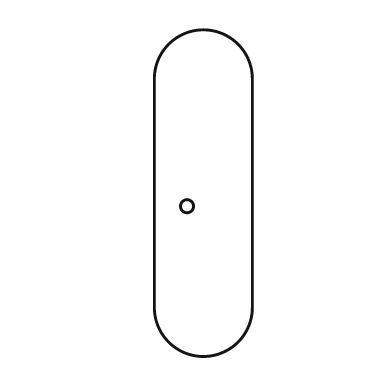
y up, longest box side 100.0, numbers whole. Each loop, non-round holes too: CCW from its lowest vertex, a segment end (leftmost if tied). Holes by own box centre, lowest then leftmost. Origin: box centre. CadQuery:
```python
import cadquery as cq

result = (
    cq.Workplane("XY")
    .moveTo(-15.0, -35.0)
    .threePointArc((0.0, -50.0), (15.0, -35.0))
    .lineTo(15.0, 35.0)
    .threePointArc((0.0, 50.0), (-15.0, 35.0))
    .close()
    .moveTo(-5.0, -4.0)
    .circle(2.0)
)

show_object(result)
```